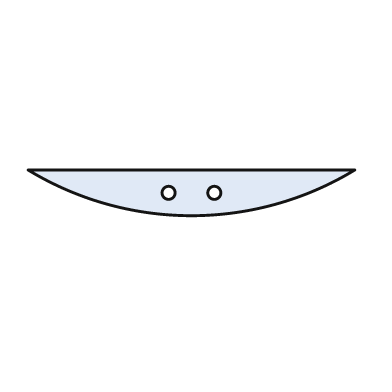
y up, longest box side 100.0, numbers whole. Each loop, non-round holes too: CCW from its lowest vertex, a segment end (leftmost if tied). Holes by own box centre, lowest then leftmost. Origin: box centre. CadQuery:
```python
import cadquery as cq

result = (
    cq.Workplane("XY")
    .moveTo(-50.0, 7.0)
    .threePointArc((0.0, -7.0), (50.0, 7.0))
    .close()
    .moveTo(-7.0, 0.0)
    .circle(2.0)
    .moveTo(7.0, 0.0)
    .circle(2.0)
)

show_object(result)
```